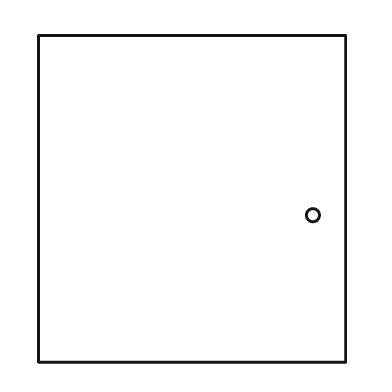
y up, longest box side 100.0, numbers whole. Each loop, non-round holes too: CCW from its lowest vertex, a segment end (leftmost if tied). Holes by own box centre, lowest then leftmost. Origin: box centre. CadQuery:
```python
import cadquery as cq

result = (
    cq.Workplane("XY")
    .moveTo(-47.0, -50.0)
    .lineTo(47.0, -50.0)
    .lineTo(47.0, 50.0)
    .lineTo(-47.0, 50.0)
    .close()
    .moveTo(37.0, -5.0)
    .circle(2.0)
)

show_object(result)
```